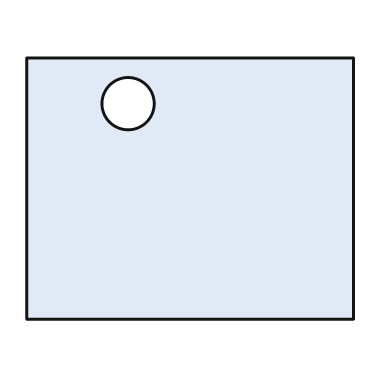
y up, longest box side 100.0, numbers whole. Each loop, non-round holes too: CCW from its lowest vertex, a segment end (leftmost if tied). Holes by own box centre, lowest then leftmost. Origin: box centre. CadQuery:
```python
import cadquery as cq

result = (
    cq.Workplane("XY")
    .moveTo(-50.0, -40.0)
    .lineTo(50.0, -40.0)
    .lineTo(50.0, 40.0)
    .lineTo(-50.0, 40.0)
    .close()
    .moveTo(-19.0, 26.0)
    .circle(8.0)
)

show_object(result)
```